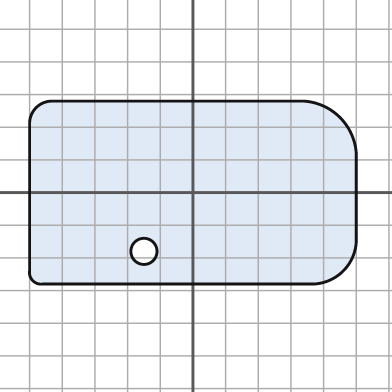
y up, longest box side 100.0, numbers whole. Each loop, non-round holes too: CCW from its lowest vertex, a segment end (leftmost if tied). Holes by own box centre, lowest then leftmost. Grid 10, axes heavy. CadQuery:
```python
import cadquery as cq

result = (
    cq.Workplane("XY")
    .moveTo(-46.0, -28.0)
    .lineTo(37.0, -28.0)
    .threePointArc((46.0, -24.0), (50.0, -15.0))
    .lineTo(50.0, 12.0)
    .threePointArc((45.0, 23.0), (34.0, 28.0))
    .lineTo(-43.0, 28.0)
    .threePointArc((-48.0, 26.0), (-50.0, 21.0))
    .lineTo(-50.0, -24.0)
    .threePointArc((-49.0, -27.0), (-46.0, -28.0))
    .close()
    .moveTo(-15.0, -18.0)
    .circle(4.0)
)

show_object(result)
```